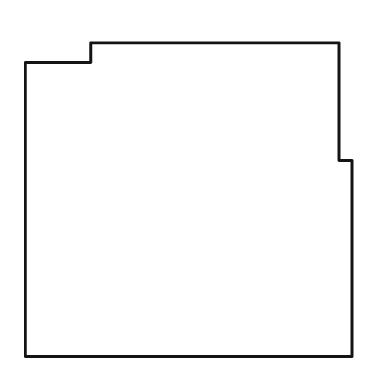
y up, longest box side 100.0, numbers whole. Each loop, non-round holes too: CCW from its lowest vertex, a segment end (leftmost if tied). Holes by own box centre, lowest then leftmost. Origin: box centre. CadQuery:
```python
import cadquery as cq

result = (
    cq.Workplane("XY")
    .moveTo(-50.0, -48.0)
    .lineTo(50.0, -48.0)
    .lineTo(50.0, 12.0)
    .lineTo(46.0, 12.0)
    .lineTo(46.0, 48.0)
    .lineTo(-30.0, 48.0)
    .lineTo(-30.0, 42.0)
    .lineTo(-50.0, 42.0)
    .close()
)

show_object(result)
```